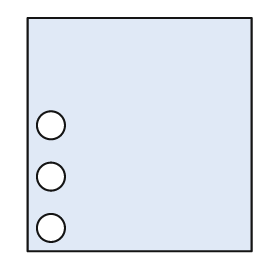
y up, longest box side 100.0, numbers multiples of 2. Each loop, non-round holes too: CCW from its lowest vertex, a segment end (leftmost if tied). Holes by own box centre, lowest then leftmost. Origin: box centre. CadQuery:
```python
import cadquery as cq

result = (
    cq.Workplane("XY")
    .moveTo(-48.0, -50.0)
    .lineTo(48.0, -50.0)
    .lineTo(48.0, 50.0)
    .lineTo(-48.0, 50.0)
    .close()
    .moveTo(-38.0, -40.0)
    .circle(6.0)
    .moveTo(-38.0, -18.0)
    .circle(6.0)
    .moveTo(-38.0, 4.0)
    .circle(6.0)
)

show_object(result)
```